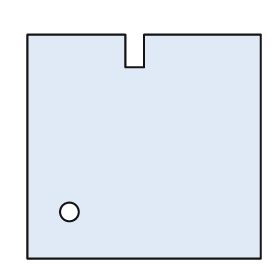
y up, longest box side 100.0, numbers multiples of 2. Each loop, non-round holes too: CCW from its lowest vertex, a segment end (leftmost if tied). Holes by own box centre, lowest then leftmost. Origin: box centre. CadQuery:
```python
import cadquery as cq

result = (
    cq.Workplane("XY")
    .moveTo(-50.0, -48.0)
    .lineTo(50.0, -48.0)
    .lineTo(50.0, 48.0)
    .lineTo(0.0, 48.0)
    .lineTo(0.0, 34.0)
    .lineTo(-8.0, 34.0)
    .lineTo(-8.0, 48.0)
    .lineTo(-50.0, 48.0)
    .close()
    .moveTo(-32.0, -28.0)
    .circle(4.0)
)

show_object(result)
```